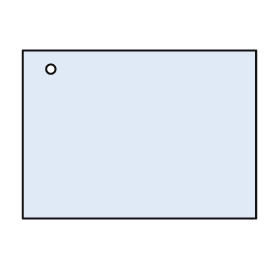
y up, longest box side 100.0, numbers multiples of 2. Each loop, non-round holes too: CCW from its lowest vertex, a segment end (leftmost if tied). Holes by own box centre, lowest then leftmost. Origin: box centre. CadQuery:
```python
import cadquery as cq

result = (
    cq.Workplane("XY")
    .moveTo(-50.0, -36.0)
    .lineTo(50.0, -36.0)
    .lineTo(50.0, 36.0)
    .lineTo(-50.0, 36.0)
    .close()
    .moveTo(-38.0, 28.0)
    .circle(2.0)
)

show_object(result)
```